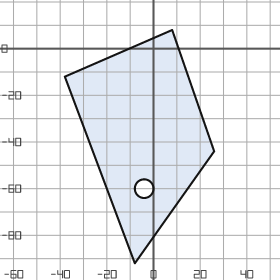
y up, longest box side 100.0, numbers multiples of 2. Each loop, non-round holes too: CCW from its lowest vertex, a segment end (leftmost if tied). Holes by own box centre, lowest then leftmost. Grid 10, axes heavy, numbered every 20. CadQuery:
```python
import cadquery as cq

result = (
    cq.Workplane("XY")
    .moveTo(-8.0, -92.0)
    .lineTo(26.0, -44.0)
    .lineTo(8.0, 8.0)
    .lineTo(-38.0, -12.0)
    .close()
    .moveTo(-4.0, -60.0)
    .circle(4.0)
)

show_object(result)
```